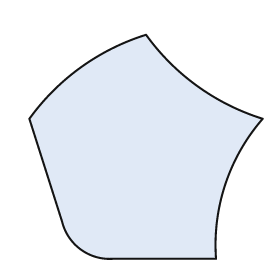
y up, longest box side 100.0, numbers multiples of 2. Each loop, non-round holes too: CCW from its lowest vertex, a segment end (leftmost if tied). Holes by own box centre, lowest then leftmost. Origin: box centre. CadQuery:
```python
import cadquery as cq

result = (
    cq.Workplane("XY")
    .moveTo(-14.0, -48.0)
    .lineTo(30.0, -48.0)
    .threePointArc((34.0, -16.0), (50.0, 12.0))
    .threePointArc((22.0, 26.0), (0.0, 48.0))
    .threePointArc((-28.0, 34.0), (-50.0, 12.0))
    .lineTo(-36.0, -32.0)
    .threePointArc((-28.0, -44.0), (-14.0, -48.0))
    .close()
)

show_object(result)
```